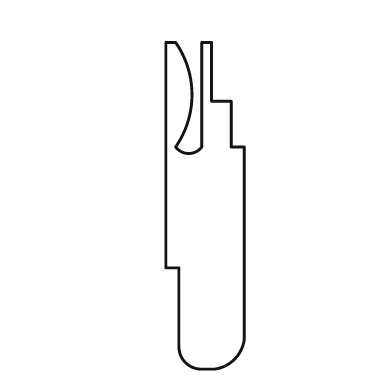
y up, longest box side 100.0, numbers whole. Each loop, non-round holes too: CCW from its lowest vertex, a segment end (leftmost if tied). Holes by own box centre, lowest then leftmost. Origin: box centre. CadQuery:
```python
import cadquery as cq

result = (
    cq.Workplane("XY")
    .moveTo(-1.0, -50.0)
    .lineTo(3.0, -50.0)
    .threePointArc((9.0, -47.0), (12.0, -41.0))
    .lineTo(12.0, 18.0)
    .lineTo(8.0, 18.0)
    .lineTo(8.0, 32.0)
    .lineTo(2.0, 32.0)
    .lineTo(2.0, 50.0)
    .lineTo(-1.0, 50.0)
    .lineTo(-1.0, 18.0)
    .threePointArc((-5.0, 16.0), (-9.0, 18.0))
    .threePointArc((-4.0, 34.0), (-9.0, 50.0))
    .lineTo(-12.0, 50.0)
    .lineTo(-12.0, -19.0)
    .lineTo(-8.0, -19.0)
    .lineTo(-8.0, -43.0)
    .threePointArc((-6.0, -48.0), (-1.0, -50.0))
    .close()
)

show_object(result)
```